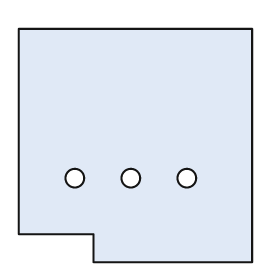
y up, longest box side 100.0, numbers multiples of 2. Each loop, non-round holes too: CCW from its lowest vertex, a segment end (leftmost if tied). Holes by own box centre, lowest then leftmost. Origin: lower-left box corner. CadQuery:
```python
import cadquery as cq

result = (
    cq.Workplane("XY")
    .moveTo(32.0, 0.0)
    .lineTo(100.0, 0.0)
    .lineTo(100.0, 100.0)
    .lineTo(0.0, 100.0)
    .lineTo(0.0, 12.0)
    .lineTo(32.0, 12.0)
    .close()
    .moveTo(24.0, 36.0)
    .circle(4.0)
    .moveTo(48.0, 36.0)
    .circle(4.0)
    .moveTo(72.0, 36.0)
    .circle(4.0)
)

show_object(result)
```